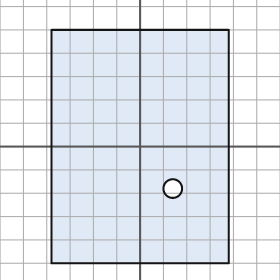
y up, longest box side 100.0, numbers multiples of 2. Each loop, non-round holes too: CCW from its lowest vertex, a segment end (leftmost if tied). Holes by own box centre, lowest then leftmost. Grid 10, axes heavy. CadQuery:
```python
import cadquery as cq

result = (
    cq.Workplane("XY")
    .moveTo(-38.0, -50.0)
    .lineTo(38.0, -50.0)
    .lineTo(38.0, 50.0)
    .lineTo(-38.0, 50.0)
    .close()
    .moveTo(14.0, -18.0)
    .circle(4.0)
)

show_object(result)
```